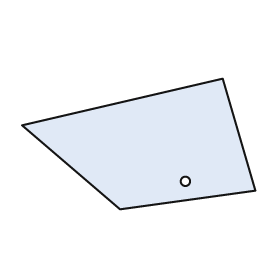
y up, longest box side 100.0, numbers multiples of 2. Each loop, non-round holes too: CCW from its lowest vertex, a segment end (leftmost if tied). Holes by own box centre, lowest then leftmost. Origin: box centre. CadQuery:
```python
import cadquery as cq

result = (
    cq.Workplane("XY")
    .moveTo(-8.0, -28.0)
    .lineTo(50.0, -20.0)
    .lineTo(36.0, 28.0)
    .lineTo(-50.0, 8.0)
    .close()
    .moveTo(20.0, -16.0)
    .circle(2.0)
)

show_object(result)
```